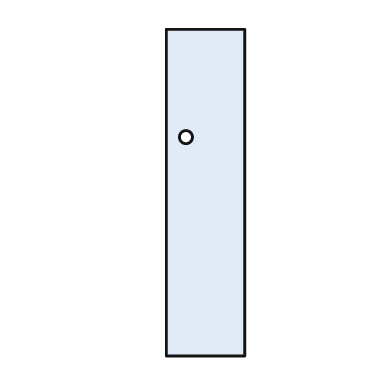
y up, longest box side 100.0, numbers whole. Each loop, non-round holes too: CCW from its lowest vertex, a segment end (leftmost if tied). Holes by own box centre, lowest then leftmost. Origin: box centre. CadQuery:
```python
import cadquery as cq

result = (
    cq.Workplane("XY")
    .moveTo(-12.0, -50.0)
    .lineTo(12.0, -50.0)
    .lineTo(12.0, 50.0)
    .lineTo(-12.0, 50.0)
    .close()
    .moveTo(-6.0, 17.0)
    .circle(2.0)
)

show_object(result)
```